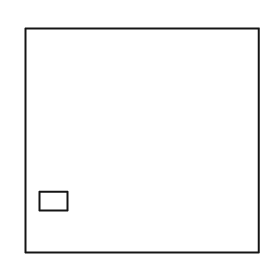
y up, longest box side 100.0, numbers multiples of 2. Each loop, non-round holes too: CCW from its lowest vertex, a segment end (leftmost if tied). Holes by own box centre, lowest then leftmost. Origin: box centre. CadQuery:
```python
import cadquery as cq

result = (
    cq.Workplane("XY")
    .moveTo(-50.0, -48.0)
    .lineTo(50.0, -48.0)
    .lineTo(50.0, 48.0)
    .lineTo(-50.0, 48.0)
    .close()
    .moveTo(-44.0, -30.0)
    .lineTo(-32.0, -30.0)
    .lineTo(-32.0, -22.0)
    .lineTo(-44.0, -22.0)
    .close()
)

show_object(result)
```